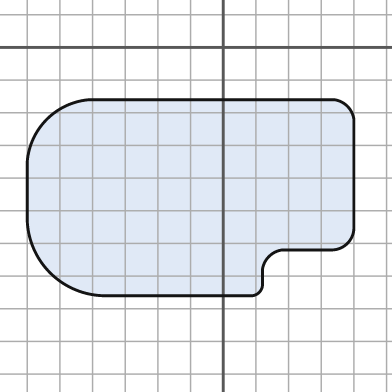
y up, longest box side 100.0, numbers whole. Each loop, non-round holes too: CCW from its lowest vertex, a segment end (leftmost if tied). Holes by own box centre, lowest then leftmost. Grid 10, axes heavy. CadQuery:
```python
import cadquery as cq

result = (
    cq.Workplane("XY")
    .moveTo(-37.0, -76.0)
    .lineTo(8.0, -76.0)
    .threePointArc((11.0, -75.0), (12.0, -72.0))
    .lineTo(12.0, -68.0)
    .threePointArc((14.0, -64.0), (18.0, -62.0))
    .lineTo(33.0, -62.0)
    .threePointArc((38.0, -60.0), (40.0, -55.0))
    .lineTo(40.0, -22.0)
    .threePointArc((38.0, -18.0), (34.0, -16.0))
    .lineTo(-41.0, -16.0)
    .threePointArc((-54.0, -22.0), (-60.0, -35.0))
    .lineTo(-60.0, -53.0)
    .threePointArc((-53.0, -69.0), (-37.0, -76.0))
    .close()
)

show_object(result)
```